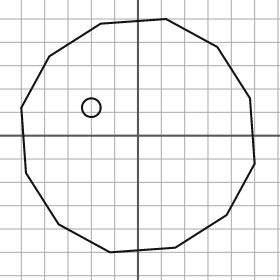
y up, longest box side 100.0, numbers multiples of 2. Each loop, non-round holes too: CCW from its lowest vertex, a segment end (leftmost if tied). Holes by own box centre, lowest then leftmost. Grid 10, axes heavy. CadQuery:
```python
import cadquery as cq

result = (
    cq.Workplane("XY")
    .moveTo(-12.0, -50.0)
    .lineTo(16.0, -48.0)
    .lineTo(38.0, -34.0)
    .lineTo(50.0, -12.0)
    .lineTo(48.0, 16.0)
    .lineTo(34.0, 38.0)
    .lineTo(12.0, 50.0)
    .lineTo(-16.0, 48.0)
    .lineTo(-38.0, 34.0)
    .lineTo(-50.0, 12.0)
    .lineTo(-48.0, -16.0)
    .lineTo(-34.0, -38.0)
    .close()
    .moveTo(-20.0, 12.0)
    .circle(4.0)
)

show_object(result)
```